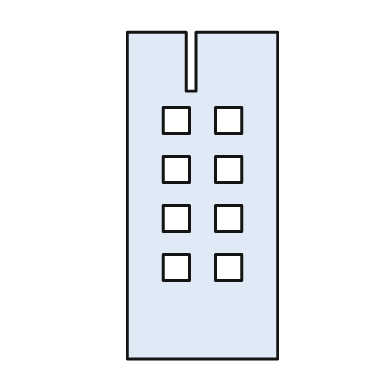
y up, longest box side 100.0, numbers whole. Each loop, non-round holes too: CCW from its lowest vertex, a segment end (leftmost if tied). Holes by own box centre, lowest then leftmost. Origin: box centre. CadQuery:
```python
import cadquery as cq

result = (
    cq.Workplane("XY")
    .moveTo(-23.0, -50.0)
    .lineTo(23.0, -50.0)
    .lineTo(23.0, 50.0)
    .lineTo(-2.0, 50.0)
    .lineTo(-2.0, 32.0)
    .lineTo(-5.0, 32.0)
    .lineTo(-5.0, 50.0)
    .lineTo(-23.0, 50.0)
    .close()
    .moveTo(-12.0, -26.0)
    .lineTo(-4.0, -26.0)
    .lineTo(-4.0, -18.0)
    .lineTo(-12.0, -18.0)
    .close()
    .moveTo(4.0, -26.0)
    .lineTo(12.0, -26.0)
    .lineTo(12.0, -18.0)
    .lineTo(4.0, -18.0)
    .close()
    .moveTo(-12.0, -11.0)
    .lineTo(-4.0, -11.0)
    .lineTo(-4.0, -3.0)
    .lineTo(-12.0, -3.0)
    .close()
    .moveTo(4.0, -11.0)
    .lineTo(12.0, -11.0)
    .lineTo(12.0, -3.0)
    .lineTo(4.0, -3.0)
    .close()
    .moveTo(-12.0, 4.0)
    .lineTo(-4.0, 4.0)
    .lineTo(-4.0, 12.0)
    .lineTo(-12.0, 12.0)
    .close()
    .moveTo(4.0, 4.0)
    .lineTo(12.0, 4.0)
    .lineTo(12.0, 12.0)
    .lineTo(4.0, 12.0)
    .close()
    .moveTo(-12.0, 19.0)
    .lineTo(-4.0, 19.0)
    .lineTo(-4.0, 27.0)
    .lineTo(-12.0, 27.0)
    .close()
    .moveTo(4.0, 19.0)
    .lineTo(12.0, 19.0)
    .lineTo(12.0, 27.0)
    .lineTo(4.0, 27.0)
    .close()
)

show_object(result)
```